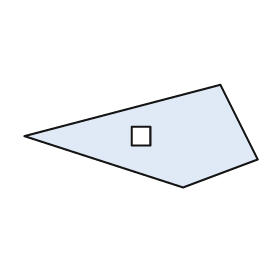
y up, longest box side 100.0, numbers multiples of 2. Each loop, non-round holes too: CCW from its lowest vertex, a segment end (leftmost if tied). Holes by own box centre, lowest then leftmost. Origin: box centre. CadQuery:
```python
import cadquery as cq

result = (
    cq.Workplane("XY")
    .moveTo(18.0, -22.0)
    .lineTo(50.0, -10.0)
    .lineTo(34.0, 22.0)
    .lineTo(-50.0, 0.0)
    .close()
    .moveTo(-4.0, -4.0)
    .lineTo(4.0, -4.0)
    .lineTo(4.0, 4.0)
    .lineTo(-4.0, 4.0)
    .close()
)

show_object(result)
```